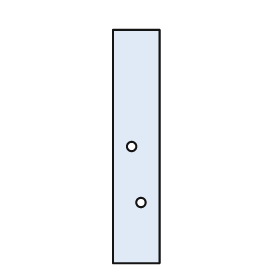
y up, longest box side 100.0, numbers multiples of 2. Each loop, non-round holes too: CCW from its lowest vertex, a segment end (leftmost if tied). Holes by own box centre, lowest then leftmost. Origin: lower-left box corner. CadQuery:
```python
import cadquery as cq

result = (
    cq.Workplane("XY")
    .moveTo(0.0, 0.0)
    .lineTo(20.0, 0.0)
    .lineTo(20.0, 100.0)
    .lineTo(0.0, 100.0)
    .close()
    .moveTo(12.0, 26.0)
    .circle(2.0)
    .moveTo(8.0, 50.0)
    .circle(2.0)
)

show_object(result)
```